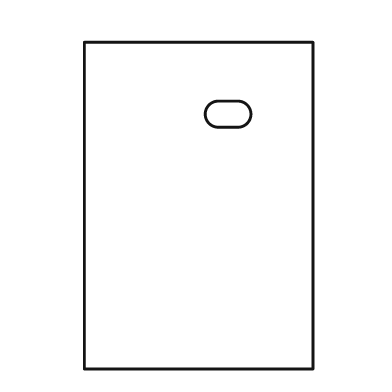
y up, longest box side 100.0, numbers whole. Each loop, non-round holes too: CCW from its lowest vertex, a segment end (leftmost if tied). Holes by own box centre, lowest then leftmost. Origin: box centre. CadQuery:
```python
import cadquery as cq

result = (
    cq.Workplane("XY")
    .moveTo(-35.0, -50.0)
    .lineTo(35.0, -50.0)
    .lineTo(35.0, 50.0)
    .lineTo(-35.0, 50.0)
    .close()
    .moveTo(6.0, 24.0)
    .lineTo(12.0, 24.0)
    .threePointArc((16.0, 28.0), (12.0, 32.0))
    .lineTo(6.0, 32.0)
    .threePointArc((2.0, 28.0), (6.0, 24.0))
    .close()
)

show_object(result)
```